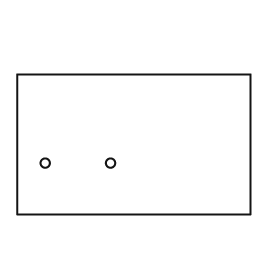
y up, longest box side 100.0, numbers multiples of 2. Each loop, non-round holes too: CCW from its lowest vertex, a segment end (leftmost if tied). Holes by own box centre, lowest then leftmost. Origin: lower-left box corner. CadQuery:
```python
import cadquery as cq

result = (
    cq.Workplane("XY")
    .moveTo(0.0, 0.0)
    .lineTo(100.0, 0.0)
    .lineTo(100.0, 60.0)
    .lineTo(0.0, 60.0)
    .close()
    .moveTo(12.0, 22.0)
    .circle(2.0)
    .moveTo(40.0, 22.0)
    .circle(2.0)
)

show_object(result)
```